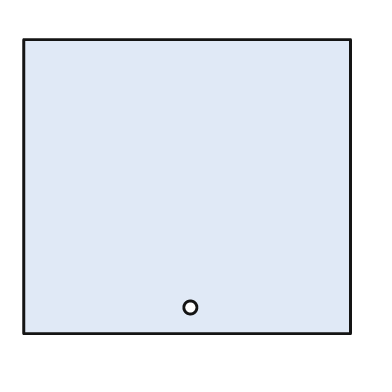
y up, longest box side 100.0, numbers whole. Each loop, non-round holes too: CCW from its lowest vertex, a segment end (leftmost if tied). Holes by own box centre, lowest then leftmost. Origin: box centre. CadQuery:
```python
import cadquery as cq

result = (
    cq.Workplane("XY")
    .moveTo(-50.0, -45.0)
    .lineTo(50.0, -45.0)
    .lineTo(50.0, 45.0)
    .lineTo(-50.0, 45.0)
    .close()
    .moveTo(1.0, -37.0)
    .circle(2.0)
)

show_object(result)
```